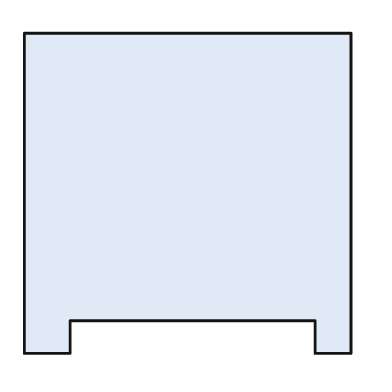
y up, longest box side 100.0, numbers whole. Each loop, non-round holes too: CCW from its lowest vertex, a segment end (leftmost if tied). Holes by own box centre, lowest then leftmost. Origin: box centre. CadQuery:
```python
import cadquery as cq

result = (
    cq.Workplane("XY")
    .moveTo(-50.0, -49.0)
    .lineTo(-36.0, -49.0)
    .lineTo(-36.0, -39.0)
    .lineTo(39.0, -39.0)
    .lineTo(39.0, -49.0)
    .lineTo(50.0, -49.0)
    .lineTo(50.0, 49.0)
    .lineTo(-50.0, 49.0)
    .close()
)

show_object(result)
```